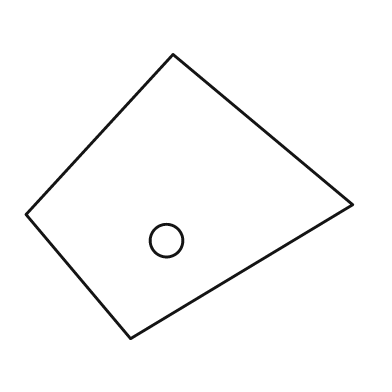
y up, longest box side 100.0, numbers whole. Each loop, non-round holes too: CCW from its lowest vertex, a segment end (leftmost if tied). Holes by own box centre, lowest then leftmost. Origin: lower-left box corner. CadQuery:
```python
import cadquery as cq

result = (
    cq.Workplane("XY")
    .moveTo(32.0, 0.0)
    .lineTo(100.0, 41.0)
    .lineTo(45.0, 87.0)
    .lineTo(0.0, 38.0)
    .close()
    .moveTo(43.0, 30.0)
    .circle(5.0)
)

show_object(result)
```